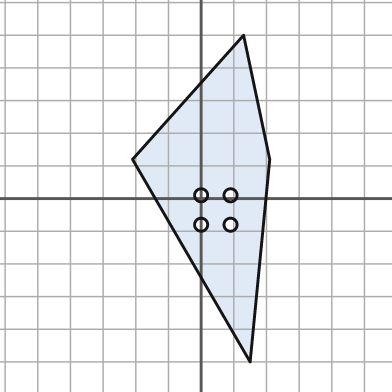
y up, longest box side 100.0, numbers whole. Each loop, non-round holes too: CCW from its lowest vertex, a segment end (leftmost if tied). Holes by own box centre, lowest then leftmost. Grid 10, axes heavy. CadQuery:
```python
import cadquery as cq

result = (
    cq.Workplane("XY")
    .moveTo(15.0, -50.0)
    .lineTo(21.0, 12.0)
    .lineTo(13.0, 50.0)
    .lineTo(-21.0, 12.0)
    .close()
    .moveTo(0.0, -8.0)
    .circle(2.0)
    .moveTo(9.0, -8.0)
    .circle(2.0)
    .moveTo(0.0, 1.0)
    .circle(2.0)
    .moveTo(9.0, 1.0)
    .circle(2.0)
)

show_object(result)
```